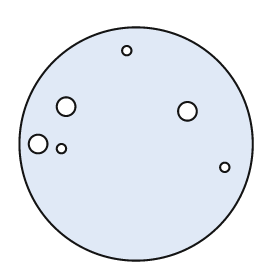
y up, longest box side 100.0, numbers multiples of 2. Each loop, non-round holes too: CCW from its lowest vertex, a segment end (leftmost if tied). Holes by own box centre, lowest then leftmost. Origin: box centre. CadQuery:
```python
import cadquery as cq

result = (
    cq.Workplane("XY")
    .moveTo(0.0, 0.0)
    .circle(50.0)
    .moveTo(38.0, -10.0)
    .circle(2.0)
    .moveTo(-32.0, -2.0)
    .circle(2.0)
    .moveTo(-42.0, 0.0)
    .circle(4.0)
    .moveTo(22.0, 14.0)
    .circle(4.0)
    .moveTo(-30.0, 16.0)
    .circle(4.0)
    .moveTo(-4.0, 40.0)
    .circle(2.0)
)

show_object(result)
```